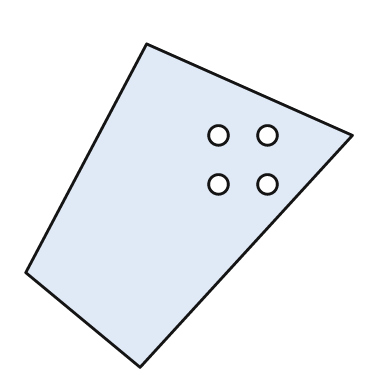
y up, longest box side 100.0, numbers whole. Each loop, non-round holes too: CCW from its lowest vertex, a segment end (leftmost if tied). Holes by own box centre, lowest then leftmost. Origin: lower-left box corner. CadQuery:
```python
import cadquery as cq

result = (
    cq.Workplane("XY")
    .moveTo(35.0, 0.0)
    .lineTo(100.0, 71.0)
    .lineTo(37.0, 99.0)
    .lineTo(0.0, 29.0)
    .close()
    .moveTo(59.0, 56.0)
    .circle(3.0)
    .moveTo(74.0, 56.0)
    .circle(3.0)
    .moveTo(59.0, 71.0)
    .circle(3.0)
    .moveTo(74.0, 71.0)
    .circle(3.0)
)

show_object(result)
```